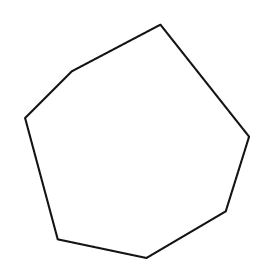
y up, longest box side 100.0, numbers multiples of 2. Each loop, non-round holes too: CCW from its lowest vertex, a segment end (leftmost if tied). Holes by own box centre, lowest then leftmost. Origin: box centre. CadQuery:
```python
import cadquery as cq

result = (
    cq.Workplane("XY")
    .moveTo(4.0, -50.0)
    .lineTo(38.0, -30.0)
    .lineTo(48.0, 2.0)
    .lineTo(10.0, 50.0)
    .lineTo(-28.0, 30.0)
    .lineTo(-48.0, 10.0)
    .lineTo(-34.0, -42.0)
    .close()
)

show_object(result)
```